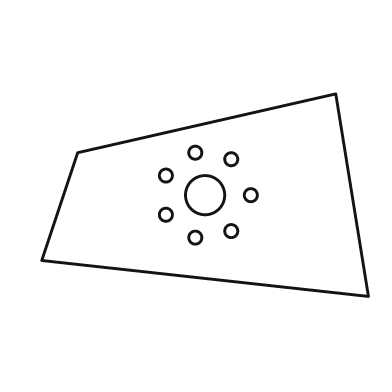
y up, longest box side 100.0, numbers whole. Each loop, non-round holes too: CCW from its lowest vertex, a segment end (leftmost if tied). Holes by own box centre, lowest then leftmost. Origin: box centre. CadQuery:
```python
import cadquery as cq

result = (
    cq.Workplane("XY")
    .moveTo(50.0, -31.0)
    .lineTo(40.0, 31.0)
    .lineTo(-39.0, 13.0)
    .lineTo(-50.0, -20.0)
    .close()
    .moveTo(-3.0, -13.0)
    .circle(2.0)
    .moveTo(8.0, -11.0)
    .circle(2.0)
    .moveTo(-12.0, -6.0)
    .circle(2.0)
    .moveTo(0.0, 0.0)
    .circle(6.0)
    .moveTo(14.0, 0.0)
    .circle(2.0)
    .moveTo(-12.0, 6.0)
    .circle(2.0)
    .moveTo(8.0, 11.0)
    .circle(2.0)
    .moveTo(-3.0, 13.0)
    .circle(2.0)
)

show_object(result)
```